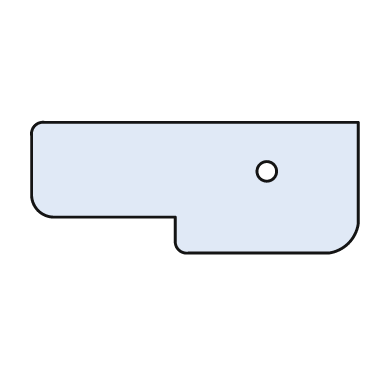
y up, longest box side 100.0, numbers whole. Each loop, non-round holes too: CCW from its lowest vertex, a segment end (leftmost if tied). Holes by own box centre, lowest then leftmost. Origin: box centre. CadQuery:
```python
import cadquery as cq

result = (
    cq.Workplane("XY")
    .moveTo(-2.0, -20.0)
    .lineTo(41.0, -20.0)
    .threePointArc((47.0, -17.0), (50.0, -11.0))
    .lineTo(50.0, 20.0)
    .lineTo(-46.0, 20.0)
    .threePointArc((-49.0, 19.0), (-50.0, 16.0))
    .lineTo(-50.0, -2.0)
    .threePointArc((-48.0, -7.0), (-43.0, -9.0))
    .lineTo(-6.0, -9.0)
    .lineTo(-6.0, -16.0)
    .threePointArc((-5.0, -19.0), (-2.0, -20.0))
    .close()
    .moveTo(22.0, 5.0)
    .circle(3.0)
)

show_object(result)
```